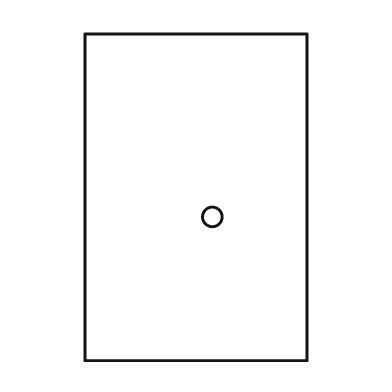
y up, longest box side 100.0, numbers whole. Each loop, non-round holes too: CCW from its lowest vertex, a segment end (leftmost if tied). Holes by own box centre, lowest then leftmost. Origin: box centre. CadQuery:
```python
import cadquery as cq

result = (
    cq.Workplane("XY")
    .moveTo(-34.0, -50.0)
    .lineTo(34.0, -50.0)
    .lineTo(34.0, 50.0)
    .lineTo(-34.0, 50.0)
    .close()
    .moveTo(5.0, -6.0)
    .circle(3.0)
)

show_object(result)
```